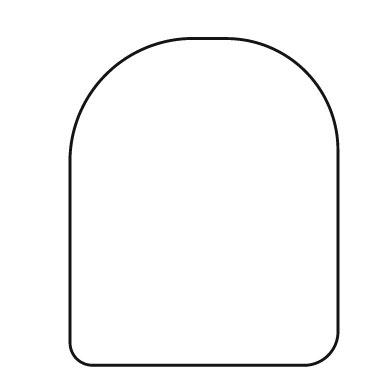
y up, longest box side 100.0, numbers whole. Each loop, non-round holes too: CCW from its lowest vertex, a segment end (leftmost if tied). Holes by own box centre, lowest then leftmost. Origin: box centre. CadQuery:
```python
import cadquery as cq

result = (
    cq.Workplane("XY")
    .moveTo(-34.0, -50.0)
    .lineTo(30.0, -50.0)
    .threePointArc((38.0, -47.0), (41.0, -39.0))
    .lineTo(41.0, 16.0)
    .threePointArc((31.0, 40.0), (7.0, 50.0))
    .lineTo(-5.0, 50.0)
    .threePointArc((-30.0, 39.0), (-41.0, 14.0))
    .lineTo(-41.0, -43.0)
    .threePointArc((-39.0, -48.0), (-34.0, -50.0))
    .close()
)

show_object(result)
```